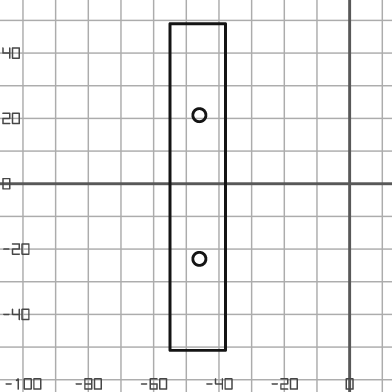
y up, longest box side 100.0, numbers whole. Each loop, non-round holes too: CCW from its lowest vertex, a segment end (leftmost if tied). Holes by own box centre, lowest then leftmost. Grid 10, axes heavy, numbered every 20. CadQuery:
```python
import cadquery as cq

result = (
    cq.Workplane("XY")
    .moveTo(-55.0, -51.0)
    .lineTo(-38.0, -51.0)
    .lineTo(-38.0, 49.0)
    .lineTo(-55.0, 49.0)
    .close()
    .moveTo(-46.0, -23.0)
    .circle(2.0)
    .moveTo(-46.0, 21.0)
    .circle(2.0)
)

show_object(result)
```